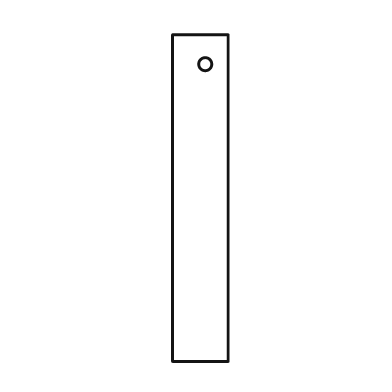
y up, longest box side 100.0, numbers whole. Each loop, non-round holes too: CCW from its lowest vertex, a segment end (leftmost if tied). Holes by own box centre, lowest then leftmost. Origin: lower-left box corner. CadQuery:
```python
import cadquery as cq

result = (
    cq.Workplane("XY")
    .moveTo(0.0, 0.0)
    .lineTo(17.0, 0.0)
    .lineTo(17.0, 100.0)
    .lineTo(0.0, 100.0)
    .close()
    .moveTo(10.0, 91.0)
    .circle(2.0)
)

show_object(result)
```